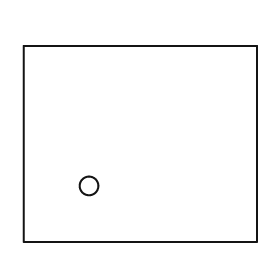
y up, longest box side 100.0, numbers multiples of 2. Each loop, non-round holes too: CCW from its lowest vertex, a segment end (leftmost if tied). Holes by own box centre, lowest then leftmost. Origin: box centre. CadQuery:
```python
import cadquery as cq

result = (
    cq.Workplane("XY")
    .moveTo(-50.0, -42.0)
    .lineTo(50.0, -42.0)
    .lineTo(50.0, 42.0)
    .lineTo(-50.0, 42.0)
    .close()
    .moveTo(-22.0, -18.0)
    .circle(4.0)
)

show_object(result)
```